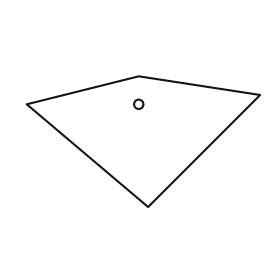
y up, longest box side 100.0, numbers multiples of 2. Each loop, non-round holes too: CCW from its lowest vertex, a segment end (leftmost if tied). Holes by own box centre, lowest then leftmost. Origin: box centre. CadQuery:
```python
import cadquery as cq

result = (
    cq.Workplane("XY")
    .moveTo(2.0, -28.0)
    .lineTo(50.0, 20.0)
    .lineTo(-2.0, 28.0)
    .lineTo(-50.0, 16.0)
    .close()
    .moveTo(-2.0, 16.0)
    .circle(2.0)
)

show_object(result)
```